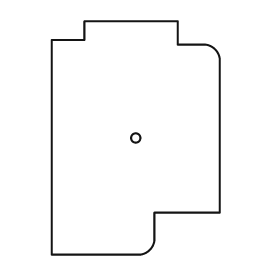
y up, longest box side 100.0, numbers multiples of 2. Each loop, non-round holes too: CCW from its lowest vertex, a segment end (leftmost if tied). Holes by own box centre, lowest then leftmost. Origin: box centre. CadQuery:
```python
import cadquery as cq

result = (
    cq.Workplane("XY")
    .moveTo(-36.0, -50.0)
    .lineTo(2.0, -50.0)
    .threePointArc((6.0, -48.0), (8.0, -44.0))
    .lineTo(8.0, -32.0)
    .lineTo(36.0, -32.0)
    .lineTo(36.0, 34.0)
    .threePointArc((34.0, 38.0), (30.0, 40.0))
    .lineTo(18.0, 40.0)
    .lineTo(18.0, 50.0)
    .lineTo(-22.0, 50.0)
    .lineTo(-22.0, 42.0)
    .lineTo(-36.0, 42.0)
    .close()
    .moveTo(0.0, 0.0)
    .circle(2.0)
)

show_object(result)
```